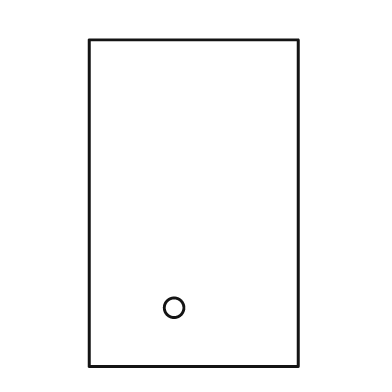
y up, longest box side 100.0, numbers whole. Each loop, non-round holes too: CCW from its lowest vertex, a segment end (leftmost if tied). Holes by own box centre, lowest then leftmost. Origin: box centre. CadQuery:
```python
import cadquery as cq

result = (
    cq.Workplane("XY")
    .moveTo(-32.0, -50.0)
    .lineTo(32.0, -50.0)
    .lineTo(32.0, 50.0)
    .lineTo(-32.0, 50.0)
    .close()
    .moveTo(-6.0, -32.0)
    .circle(3.0)
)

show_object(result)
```